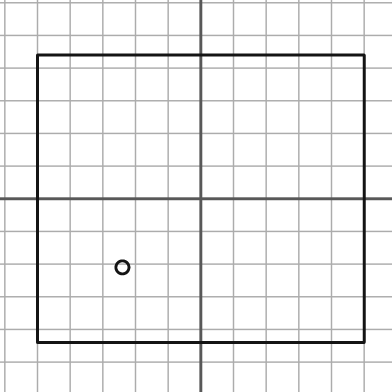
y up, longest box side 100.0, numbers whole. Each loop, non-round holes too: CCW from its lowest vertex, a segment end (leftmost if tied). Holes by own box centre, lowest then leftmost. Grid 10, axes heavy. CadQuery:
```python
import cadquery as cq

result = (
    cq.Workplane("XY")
    .moveTo(-50.0, -44.0)
    .lineTo(50.0, -44.0)
    .lineTo(50.0, 44.0)
    .lineTo(-50.0, 44.0)
    .close()
    .moveTo(-24.0, -21.0)
    .circle(2.0)
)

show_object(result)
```